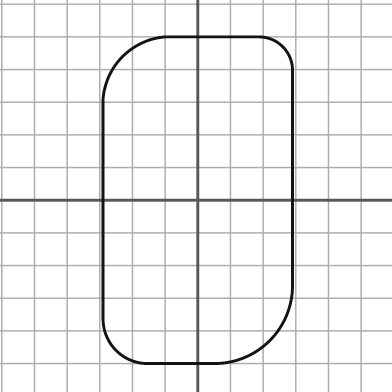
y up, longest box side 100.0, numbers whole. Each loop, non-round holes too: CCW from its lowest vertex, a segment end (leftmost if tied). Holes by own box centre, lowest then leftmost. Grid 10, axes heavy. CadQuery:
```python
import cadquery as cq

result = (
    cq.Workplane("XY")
    .moveTo(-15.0, -50.0)
    .lineTo(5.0, -50.0)
    .threePointArc((22.0, -43.0), (29.0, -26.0))
    .lineTo(29.0, 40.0)
    .threePointArc((26.0, 47.0), (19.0, 50.0))
    .lineTo(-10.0, 50.0)
    .threePointArc((-23.0, 44.0), (-29.0, 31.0))
    .lineTo(-29.0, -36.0)
    .threePointArc((-25.0, -46.0), (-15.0, -50.0))
    .close()
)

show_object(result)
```